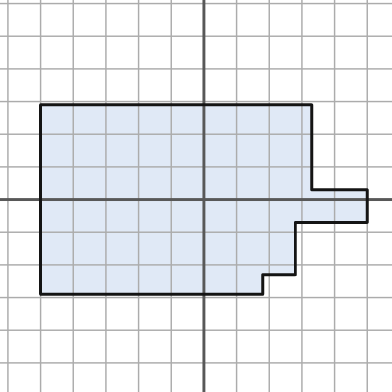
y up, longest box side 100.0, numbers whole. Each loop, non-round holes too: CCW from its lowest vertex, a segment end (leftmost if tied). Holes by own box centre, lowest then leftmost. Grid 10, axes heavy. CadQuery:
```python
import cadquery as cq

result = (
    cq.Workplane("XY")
    .moveTo(-50.0, -29.0)
    .lineTo(18.0, -29.0)
    .lineTo(18.0, -23.0)
    .lineTo(28.0, -23.0)
    .lineTo(28.0, -7.0)
    .lineTo(50.0, -7.0)
    .lineTo(50.0, 3.0)
    .lineTo(33.0, 3.0)
    .lineTo(33.0, 29.0)
    .lineTo(-50.0, 29.0)
    .close()
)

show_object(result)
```